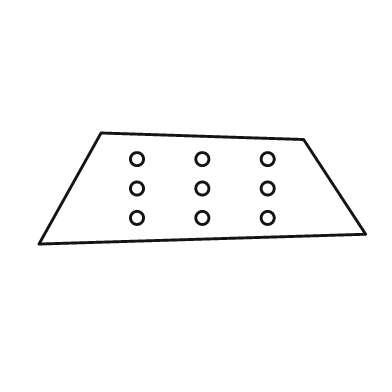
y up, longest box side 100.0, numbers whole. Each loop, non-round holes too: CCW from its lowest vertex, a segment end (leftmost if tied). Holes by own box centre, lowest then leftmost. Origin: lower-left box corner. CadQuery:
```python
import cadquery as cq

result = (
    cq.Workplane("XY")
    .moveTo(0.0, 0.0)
    .lineTo(100.0, 3.0)
    .lineTo(81.0, 32.0)
    .lineTo(19.0, 34.0)
    .close()
    .moveTo(30.0, 8.0)
    .circle(2.0)
    .moveTo(50.0, 8.0)
    .circle(2.0)
    .moveTo(70.0, 8.0)
    .circle(2.0)
    .moveTo(30.0, 17.0)
    .circle(2.0)
    .moveTo(50.0, 17.0)
    .circle(2.0)
    .moveTo(70.0, 17.0)
    .circle(2.0)
    .moveTo(30.0, 26.0)
    .circle(2.0)
    .moveTo(50.0, 26.0)
    .circle(2.0)
    .moveTo(70.0, 26.0)
    .circle(2.0)
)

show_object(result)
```